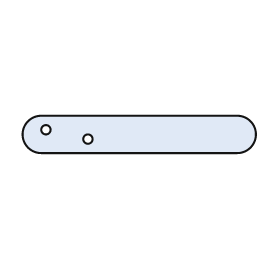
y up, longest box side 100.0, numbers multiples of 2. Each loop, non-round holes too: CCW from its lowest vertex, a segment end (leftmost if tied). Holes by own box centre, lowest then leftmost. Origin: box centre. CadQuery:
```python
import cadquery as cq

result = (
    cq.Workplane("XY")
    .moveTo(-42.0, -8.0)
    .lineTo(42.0, -8.0)
    .threePointArc((50.0, 0.0), (42.0, 8.0))
    .lineTo(-42.0, 8.0)
    .threePointArc((-50.0, 0.0), (-42.0, -8.0))
    .close()
    .moveTo(-22.0, -2.0)
    .circle(2.0)
    .moveTo(-40.0, 2.0)
    .circle(2.0)
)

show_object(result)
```